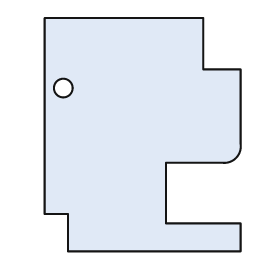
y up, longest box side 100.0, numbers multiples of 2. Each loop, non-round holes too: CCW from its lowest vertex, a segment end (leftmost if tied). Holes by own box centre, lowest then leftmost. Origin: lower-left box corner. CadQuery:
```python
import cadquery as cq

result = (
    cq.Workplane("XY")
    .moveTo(10.0, 0.0)
    .lineTo(84.0, 0.0)
    .lineTo(84.0, 12.0)
    .lineTo(52.0, 12.0)
    .lineTo(52.0, 38.0)
    .lineTo(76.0, 38.0)
    .threePointArc((82.0, 40.0), (84.0, 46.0))
    .lineTo(84.0, 78.0)
    .lineTo(68.0, 78.0)
    .lineTo(68.0, 100.0)
    .lineTo(0.0, 100.0)
    .lineTo(0.0, 16.0)
    .lineTo(10.0, 16.0)
    .close()
    .moveTo(8.0, 70.0)
    .circle(4.0)
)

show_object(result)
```